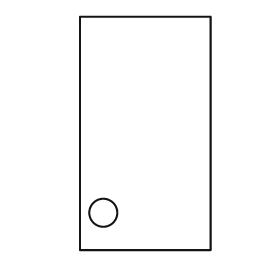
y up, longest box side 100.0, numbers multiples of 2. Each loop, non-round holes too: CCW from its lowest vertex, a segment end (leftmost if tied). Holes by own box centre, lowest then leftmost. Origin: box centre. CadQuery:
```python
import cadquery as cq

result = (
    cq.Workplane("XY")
    .moveTo(-28.0, -50.0)
    .lineTo(28.0, -50.0)
    .lineTo(28.0, 50.0)
    .lineTo(-28.0, 50.0)
    .close()
    .moveTo(-18.0, -34.0)
    .circle(6.0)
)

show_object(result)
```